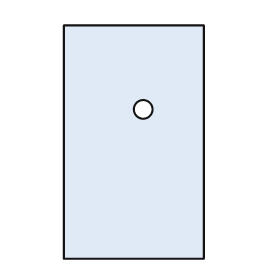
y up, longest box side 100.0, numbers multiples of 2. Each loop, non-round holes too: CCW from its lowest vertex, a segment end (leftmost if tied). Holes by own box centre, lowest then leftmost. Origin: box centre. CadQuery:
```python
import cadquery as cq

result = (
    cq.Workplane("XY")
    .moveTo(-30.0, -50.0)
    .lineTo(30.0, -50.0)
    .lineTo(30.0, 50.0)
    .lineTo(-30.0, 50.0)
    .close()
    .moveTo(4.0, 14.0)
    .circle(4.0)
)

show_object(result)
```